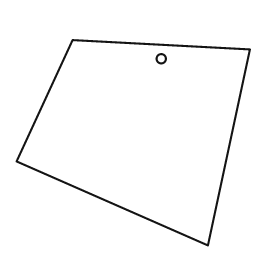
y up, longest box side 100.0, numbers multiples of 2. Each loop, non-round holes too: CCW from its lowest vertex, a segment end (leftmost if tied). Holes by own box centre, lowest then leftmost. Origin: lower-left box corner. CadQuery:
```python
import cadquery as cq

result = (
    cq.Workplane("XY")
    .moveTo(82.0, 0.0)
    .lineTo(100.0, 84.0)
    .lineTo(24.0, 88.0)
    .lineTo(0.0, 36.0)
    .close()
    .moveTo(62.0, 80.0)
    .circle(2.0)
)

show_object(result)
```